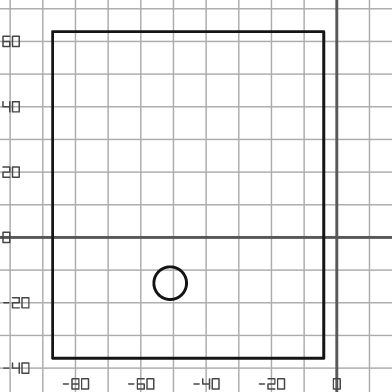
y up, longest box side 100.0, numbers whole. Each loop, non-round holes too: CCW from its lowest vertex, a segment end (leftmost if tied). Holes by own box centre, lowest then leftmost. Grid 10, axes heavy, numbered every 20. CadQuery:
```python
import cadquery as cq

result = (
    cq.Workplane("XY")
    .moveTo(-87.0, -37.0)
    .lineTo(-4.0, -37.0)
    .lineTo(-4.0, 63.0)
    .lineTo(-87.0, 63.0)
    .close()
    .moveTo(-51.0, -14.0)
    .circle(5.0)
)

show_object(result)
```